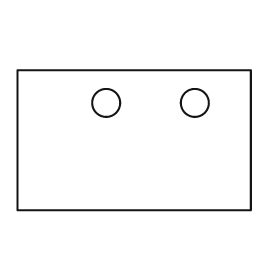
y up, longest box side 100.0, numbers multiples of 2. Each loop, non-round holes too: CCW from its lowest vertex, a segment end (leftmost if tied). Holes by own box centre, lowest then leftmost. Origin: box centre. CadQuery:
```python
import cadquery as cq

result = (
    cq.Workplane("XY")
    .moveTo(-50.0, -30.0)
    .lineTo(50.0, -30.0)
    .lineTo(50.0, 30.0)
    .lineTo(-50.0, 30.0)
    .close()
    .moveTo(-12.0, 16.0)
    .circle(6.0)
    .moveTo(26.0, 16.0)
    .circle(6.0)
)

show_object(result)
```